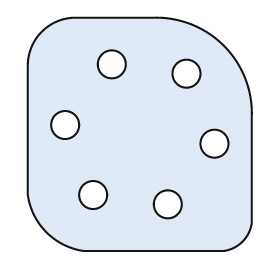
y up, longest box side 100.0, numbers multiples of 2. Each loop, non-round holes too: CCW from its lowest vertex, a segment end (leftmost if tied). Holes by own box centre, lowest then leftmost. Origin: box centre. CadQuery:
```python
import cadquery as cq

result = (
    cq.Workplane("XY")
    .moveTo(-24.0, -50.0)
    .lineTo(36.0, -50.0)
    .threePointArc((44.0, -46.0), (48.0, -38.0))
    .lineTo(48.0, 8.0)
    .threePointArc((36.0, 38.0), (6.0, 50.0))
    .lineTo(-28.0, 50.0)
    .threePointArc((-42.0, 44.0), (-48.0, 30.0))
    .lineTo(-48.0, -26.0)
    .threePointArc((-40.0, -42.0), (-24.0, -50.0))
    .close()
    .moveTo(12.0, -30.0)
    .circle(6.0)
    .moveTo(-20.0, -26.0)
    .circle(6.0)
    .moveTo(32.0, -4.0)
    .circle(6.0)
    .moveTo(-32.0, 4.0)
    .circle(6.0)
    .moveTo(20.0, 26.0)
    .circle(6.0)
    .moveTo(-12.0, 30.0)
    .circle(6.0)
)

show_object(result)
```